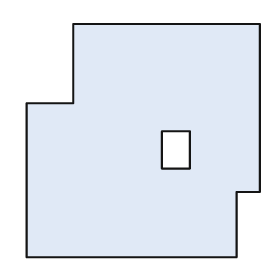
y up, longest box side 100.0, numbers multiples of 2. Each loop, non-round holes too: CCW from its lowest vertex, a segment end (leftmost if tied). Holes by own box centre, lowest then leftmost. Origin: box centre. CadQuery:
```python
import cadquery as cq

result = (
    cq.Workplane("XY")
    .moveTo(-50.0, -50.0)
    .lineTo(40.0, -50.0)
    .lineTo(40.0, -22.0)
    .lineTo(50.0, -22.0)
    .lineTo(50.0, 50.0)
    .lineTo(-30.0, 50.0)
    .lineTo(-30.0, 16.0)
    .lineTo(-50.0, 16.0)
    .close()
    .moveTo(8.0, -12.0)
    .lineTo(20.0, -12.0)
    .lineTo(20.0, 4.0)
    .lineTo(8.0, 4.0)
    .close()
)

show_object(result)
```